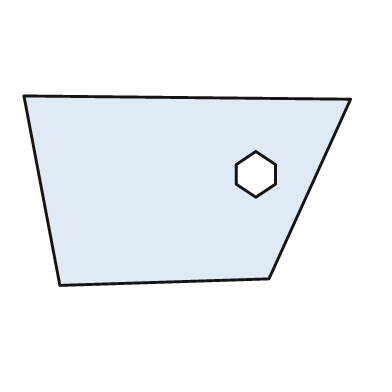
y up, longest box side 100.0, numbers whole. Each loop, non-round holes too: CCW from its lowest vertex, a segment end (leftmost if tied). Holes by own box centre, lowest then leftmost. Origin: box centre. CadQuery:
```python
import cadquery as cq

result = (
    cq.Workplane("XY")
    .moveTo(-39.0, -29.0)
    .lineTo(25.0, -27.0)
    .lineTo(50.0, 28.0)
    .lineTo(-50.0, 29.0)
    .close()
    .moveTo(21.0, -2.0)
    .lineTo(27.0, 2.0)
    .lineTo(27.0, 8.0)
    .lineTo(21.0, 12.0)
    .lineTo(15.0, 8.0)
    .lineTo(15.0, 2.0)
    .close()
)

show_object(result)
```